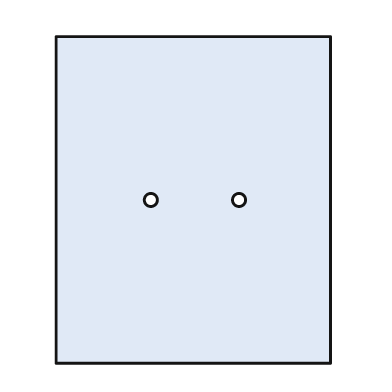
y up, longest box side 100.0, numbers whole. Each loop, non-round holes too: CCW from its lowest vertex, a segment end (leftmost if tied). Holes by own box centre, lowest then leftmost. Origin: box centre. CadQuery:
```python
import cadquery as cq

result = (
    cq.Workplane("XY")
    .moveTo(-42.0, -50.0)
    .lineTo(42.0, -50.0)
    .lineTo(42.0, 50.0)
    .lineTo(-42.0, 50.0)
    .close()
    .moveTo(-13.0, 0.0)
    .circle(2.0)
    .moveTo(14.0, 0.0)
    .circle(2.0)
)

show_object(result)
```